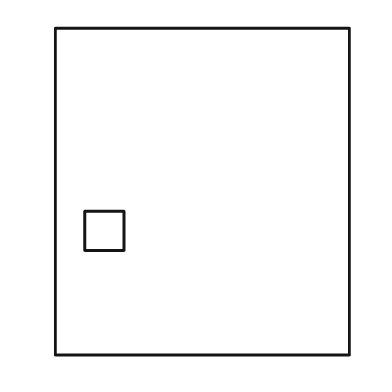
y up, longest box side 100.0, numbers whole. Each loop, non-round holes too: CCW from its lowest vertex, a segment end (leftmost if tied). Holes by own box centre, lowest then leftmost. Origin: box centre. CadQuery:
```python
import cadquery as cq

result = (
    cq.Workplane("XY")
    .moveTo(-45.0, -50.0)
    .lineTo(45.0, -50.0)
    .lineTo(45.0, 50.0)
    .lineTo(-45.0, 50.0)
    .close()
    .moveTo(-36.0, -18.0)
    .lineTo(-24.0, -18.0)
    .lineTo(-24.0, -6.0)
    .lineTo(-36.0, -6.0)
    .close()
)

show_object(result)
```